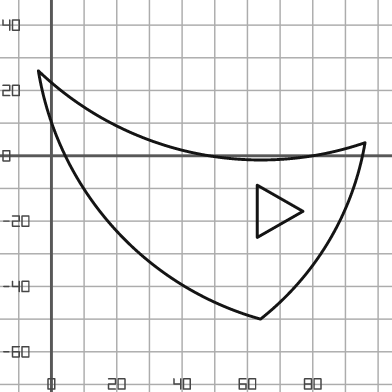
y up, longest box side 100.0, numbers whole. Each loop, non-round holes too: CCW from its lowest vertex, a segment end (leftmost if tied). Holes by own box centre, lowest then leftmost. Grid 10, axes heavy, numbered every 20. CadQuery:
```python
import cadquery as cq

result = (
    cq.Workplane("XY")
    .moveTo(64.0, -50.0)
    .threePointArc((85.0, -26.0), (96.0, 4.0))
    .threePointArc((43.0, 1.0), (-4.0, 26.0))
    .threePointArc((19.0, -22.0), (64.0, -50.0))
    .close()
    .moveTo(63.0, -25.0)
    .lineTo(77.0, -17.0)
    .lineTo(63.0, -9.0)
    .close()
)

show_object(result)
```